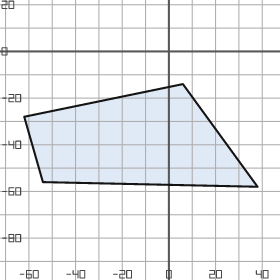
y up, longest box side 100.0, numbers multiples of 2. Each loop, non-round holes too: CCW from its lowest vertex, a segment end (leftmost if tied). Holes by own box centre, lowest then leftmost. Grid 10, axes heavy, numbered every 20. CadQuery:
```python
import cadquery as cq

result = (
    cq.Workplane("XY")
    .moveTo(38.0, -58.0)
    .lineTo(6.0, -14.0)
    .lineTo(-62.0, -28.0)
    .lineTo(-54.0, -56.0)
    .close()
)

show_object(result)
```